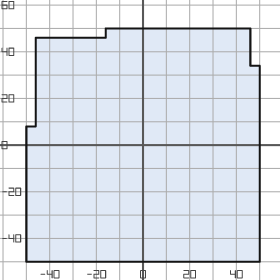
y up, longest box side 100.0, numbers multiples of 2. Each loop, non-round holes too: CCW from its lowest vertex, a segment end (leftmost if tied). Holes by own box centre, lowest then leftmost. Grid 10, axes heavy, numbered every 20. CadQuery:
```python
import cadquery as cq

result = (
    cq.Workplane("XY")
    .moveTo(-50.0, -50.0)
    .lineTo(50.0, -50.0)
    .lineTo(50.0, 34.0)
    .lineTo(46.0, 34.0)
    .lineTo(46.0, 50.0)
    .lineTo(-16.0, 50.0)
    .lineTo(-16.0, 46.0)
    .lineTo(-46.0, 46.0)
    .lineTo(-46.0, 8.0)
    .lineTo(-50.0, 8.0)
    .close()
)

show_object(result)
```